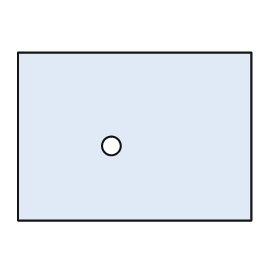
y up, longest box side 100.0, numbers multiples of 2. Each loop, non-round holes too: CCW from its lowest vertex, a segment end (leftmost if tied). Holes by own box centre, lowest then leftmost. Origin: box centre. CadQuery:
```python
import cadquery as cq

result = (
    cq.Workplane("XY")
    .moveTo(-50.0, -36.0)
    .lineTo(50.0, -36.0)
    .lineTo(50.0, 36.0)
    .lineTo(-50.0, 36.0)
    .close()
    .moveTo(-10.0, -4.0)
    .circle(4.0)
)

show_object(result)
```